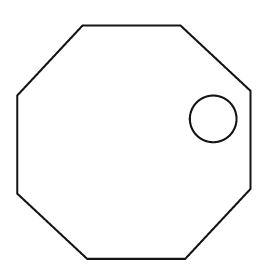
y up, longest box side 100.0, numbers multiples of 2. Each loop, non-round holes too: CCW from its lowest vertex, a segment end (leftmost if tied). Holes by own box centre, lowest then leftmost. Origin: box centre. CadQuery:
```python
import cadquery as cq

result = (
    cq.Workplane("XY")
    .moveTo(-20.0, -50.0)
    .lineTo(22.0, -50.0)
    .lineTo(50.0, -20.0)
    .lineTo(50.0, 22.0)
    .lineTo(20.0, 50.0)
    .lineTo(-22.0, 50.0)
    .lineTo(-50.0, 20.0)
    .lineTo(-50.0, -22.0)
    .close()
    .moveTo(34.0, 10.0)
    .circle(10.0)
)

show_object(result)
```